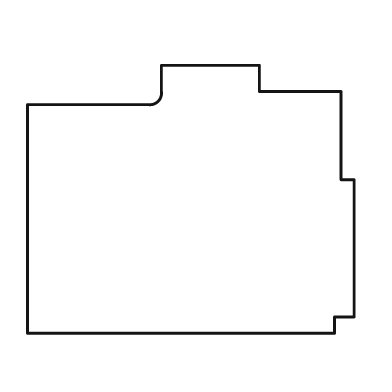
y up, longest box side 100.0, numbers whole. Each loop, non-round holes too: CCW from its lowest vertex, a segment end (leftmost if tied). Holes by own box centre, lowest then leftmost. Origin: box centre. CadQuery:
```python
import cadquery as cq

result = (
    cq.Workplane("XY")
    .moveTo(-50.0, -41.0)
    .lineTo(44.0, -41.0)
    .lineTo(44.0, -36.0)
    .lineTo(50.0, -36.0)
    .lineTo(50.0, 6.0)
    .lineTo(46.0, 6.0)
    .lineTo(46.0, 33.0)
    .lineTo(21.0, 33.0)
    .lineTo(21.0, 41.0)
    .lineTo(-9.0, 41.0)
    .lineTo(-9.0, 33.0)
    .threePointArc((-10.0, 30.0), (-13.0, 29.0))
    .lineTo(-50.0, 29.0)
    .close()
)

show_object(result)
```